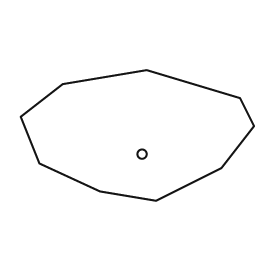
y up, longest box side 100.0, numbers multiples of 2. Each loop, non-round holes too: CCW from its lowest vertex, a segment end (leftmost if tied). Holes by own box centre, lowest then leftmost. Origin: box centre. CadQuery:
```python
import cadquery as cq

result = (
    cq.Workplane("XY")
    .moveTo(8.0, -28.0)
    .lineTo(36.0, -14.0)
    .lineTo(50.0, 4.0)
    .lineTo(44.0, 16.0)
    .lineTo(4.0, 28.0)
    .lineTo(-32.0, 22.0)
    .lineTo(-50.0, 8.0)
    .lineTo(-42.0, -12.0)
    .lineTo(-16.0, -24.0)
    .close()
    .moveTo(2.0, -8.0)
    .circle(2.0)
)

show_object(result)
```